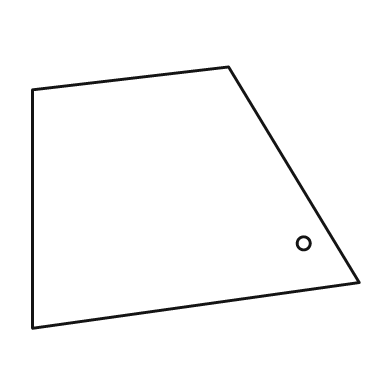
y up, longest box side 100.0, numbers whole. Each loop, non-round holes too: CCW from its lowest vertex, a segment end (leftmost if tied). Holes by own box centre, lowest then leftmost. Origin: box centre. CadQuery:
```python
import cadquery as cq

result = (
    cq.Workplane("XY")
    .moveTo(-50.0, -40.0)
    .lineTo(50.0, -26.0)
    .lineTo(10.0, 40.0)
    .lineTo(-50.0, 33.0)
    .close()
    .moveTo(33.0, -14.0)
    .circle(2.0)
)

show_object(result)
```